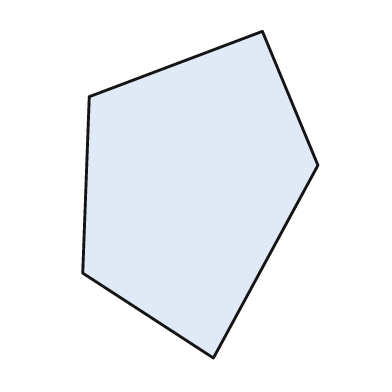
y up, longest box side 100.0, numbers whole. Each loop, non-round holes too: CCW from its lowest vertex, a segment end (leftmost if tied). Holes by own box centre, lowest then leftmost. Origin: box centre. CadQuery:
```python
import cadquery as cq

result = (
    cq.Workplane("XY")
    .moveTo(4.0, -50.0)
    .lineTo(36.0, 9.0)
    .lineTo(19.0, 50.0)
    .lineTo(-34.0, 30.0)
    .lineTo(-36.0, -24.0)
    .close()
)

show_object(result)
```